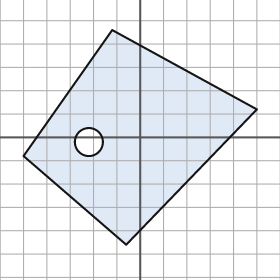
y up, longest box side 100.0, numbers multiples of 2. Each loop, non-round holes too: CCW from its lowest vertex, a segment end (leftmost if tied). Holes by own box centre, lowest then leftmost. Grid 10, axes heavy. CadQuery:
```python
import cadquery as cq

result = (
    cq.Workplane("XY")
    .moveTo(-6.0, -46.0)
    .lineTo(50.0, 12.0)
    .lineTo(-12.0, 46.0)
    .lineTo(-50.0, -8.0)
    .close()
    .moveTo(-22.0, -2.0)
    .circle(6.0)
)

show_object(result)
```